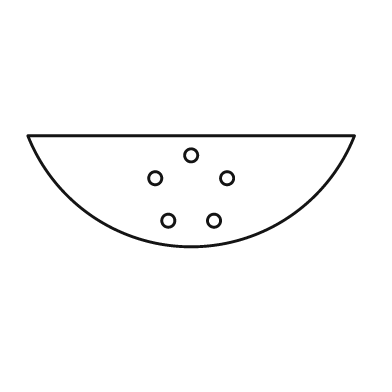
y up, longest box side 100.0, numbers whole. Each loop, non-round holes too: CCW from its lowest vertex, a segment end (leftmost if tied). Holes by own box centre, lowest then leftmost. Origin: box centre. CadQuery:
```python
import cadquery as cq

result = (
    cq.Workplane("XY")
    .moveTo(-50.0, 17.0)
    .threePointArc((0.0, -17.0), (50.0, 17.0))
    .close()
    .moveTo(-7.0, -9.0)
    .circle(2.0)
    .moveTo(7.0, -9.0)
    .circle(2.0)
    .moveTo(-11.0, 4.0)
    .circle(2.0)
    .moveTo(11.0, 4.0)
    .circle(2.0)
    .moveTo(0.0, 11.0)
    .circle(2.0)
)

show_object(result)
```